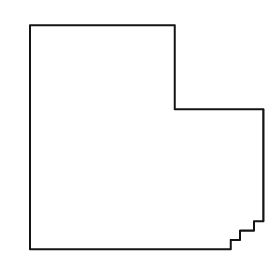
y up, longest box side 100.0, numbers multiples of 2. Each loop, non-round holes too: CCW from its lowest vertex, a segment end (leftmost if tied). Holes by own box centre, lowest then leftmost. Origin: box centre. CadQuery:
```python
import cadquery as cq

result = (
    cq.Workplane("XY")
    .moveTo(-50.0, -48.0)
    .lineTo(36.0, -48.0)
    .lineTo(36.0, -44.0)
    .lineTo(40.0, -44.0)
    .lineTo(40.0, -40.0)
    .lineTo(46.0, -40.0)
    .lineTo(46.0, -36.0)
    .lineTo(50.0, -36.0)
    .lineTo(50.0, 12.0)
    .lineTo(12.0, 12.0)
    .lineTo(12.0, 48.0)
    .lineTo(-50.0, 48.0)
    .close()
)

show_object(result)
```